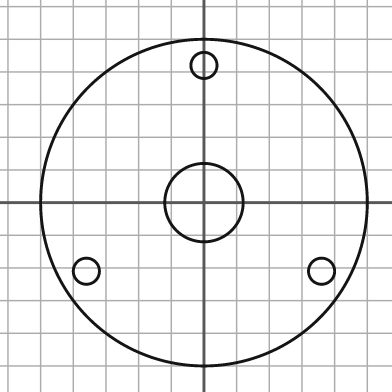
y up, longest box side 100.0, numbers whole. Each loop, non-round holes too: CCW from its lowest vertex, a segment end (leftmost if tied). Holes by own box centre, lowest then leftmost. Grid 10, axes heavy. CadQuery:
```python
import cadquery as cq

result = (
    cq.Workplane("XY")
    .moveTo(0.0, 0.0)
    .circle(50.0)
    .moveTo(-36.0, -21.0)
    .circle(4.0)
    .moveTo(36.0, -21.0)
    .circle(4.0)
    .moveTo(0.0, 0.0)
    .circle(12.0)
    .moveTo(0.0, 42.0)
    .circle(4.0)
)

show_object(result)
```